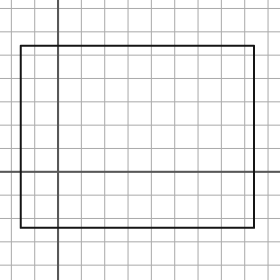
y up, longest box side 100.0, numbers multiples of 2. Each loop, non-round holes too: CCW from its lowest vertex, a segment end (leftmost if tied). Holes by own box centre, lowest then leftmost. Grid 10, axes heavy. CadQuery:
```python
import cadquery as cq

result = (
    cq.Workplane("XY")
    .moveTo(-16.0, -24.0)
    .lineTo(84.0, -24.0)
    .lineTo(84.0, 54.0)
    .lineTo(-16.0, 54.0)
    .close()
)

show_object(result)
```